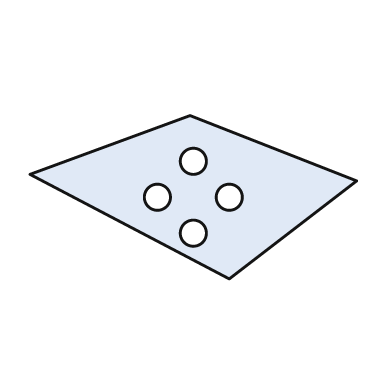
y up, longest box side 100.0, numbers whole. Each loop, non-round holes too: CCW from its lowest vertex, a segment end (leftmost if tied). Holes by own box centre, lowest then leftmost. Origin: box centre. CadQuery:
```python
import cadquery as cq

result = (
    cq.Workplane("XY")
    .moveTo(11.0, -25.0)
    .lineTo(50.0, 5.0)
    .lineTo(-1.0, 25.0)
    .lineTo(-50.0, 7.0)
    .close()
    .moveTo(0.0, -11.0)
    .circle(4.0)
    .moveTo(-11.0, 0.0)
    .circle(4.0)
    .moveTo(11.0, 0.0)
    .circle(4.0)
    .moveTo(0.0, 11.0)
    .circle(4.0)
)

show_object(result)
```